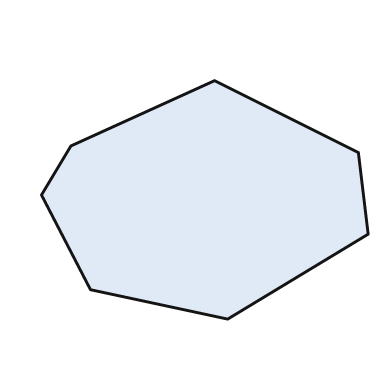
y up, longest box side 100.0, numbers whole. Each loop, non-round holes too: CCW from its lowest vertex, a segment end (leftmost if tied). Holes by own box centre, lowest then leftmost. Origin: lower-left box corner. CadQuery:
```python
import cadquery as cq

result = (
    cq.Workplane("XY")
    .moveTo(57.0, 0.0)
    .lineTo(100.0, 26.0)
    .lineTo(97.0, 51.0)
    .lineTo(53.0, 73.0)
    .lineTo(9.0, 53.0)
    .lineTo(0.0, 38.0)
    .lineTo(15.0, 9.0)
    .close()
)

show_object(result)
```